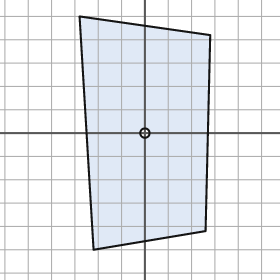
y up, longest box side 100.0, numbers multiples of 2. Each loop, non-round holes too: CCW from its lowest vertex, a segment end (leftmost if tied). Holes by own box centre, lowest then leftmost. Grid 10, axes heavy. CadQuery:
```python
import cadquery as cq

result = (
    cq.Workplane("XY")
    .moveTo(-22.0, -50.0)
    .lineTo(26.0, -42.0)
    .lineTo(28.0, 42.0)
    .lineTo(-28.0, 50.0)
    .close()
    .moveTo(0.0, 0.0)
    .circle(2.0)
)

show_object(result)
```